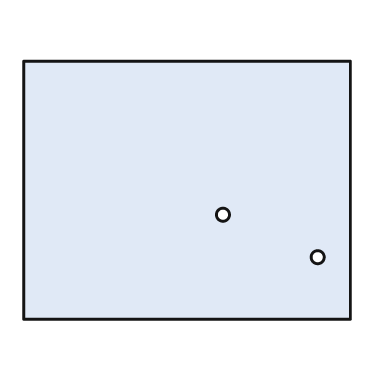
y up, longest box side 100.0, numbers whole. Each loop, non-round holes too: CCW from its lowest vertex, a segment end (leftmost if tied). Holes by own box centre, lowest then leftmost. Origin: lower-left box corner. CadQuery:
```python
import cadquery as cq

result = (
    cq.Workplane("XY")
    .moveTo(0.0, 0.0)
    .lineTo(100.0, 0.0)
    .lineTo(100.0, 79.0)
    .lineTo(0.0, 79.0)
    .close()
    .moveTo(90.0, 19.0)
    .circle(2.0)
    .moveTo(61.0, 32.0)
    .circle(2.0)
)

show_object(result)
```